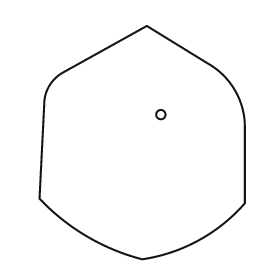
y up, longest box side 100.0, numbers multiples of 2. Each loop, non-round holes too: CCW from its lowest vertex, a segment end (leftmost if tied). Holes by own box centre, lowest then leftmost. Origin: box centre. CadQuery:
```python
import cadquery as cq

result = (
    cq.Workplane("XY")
    .moveTo(0.0, -50.0)
    .threePointArc((24.0, -42.0), (44.0, -26.0))
    .lineTo(44.0, 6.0)
    .threePointArc((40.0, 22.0), (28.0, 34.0))
    .lineTo(2.0, 50.0)
    .lineTo(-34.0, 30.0)
    .threePointArc((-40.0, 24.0), (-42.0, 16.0))
    .lineTo(-44.0, -24.0)
    .threePointArc((-24.0, -40.0), (0.0, -50.0))
    .close()
    .moveTo(8.0, 12.0)
    .circle(2.0)
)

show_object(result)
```